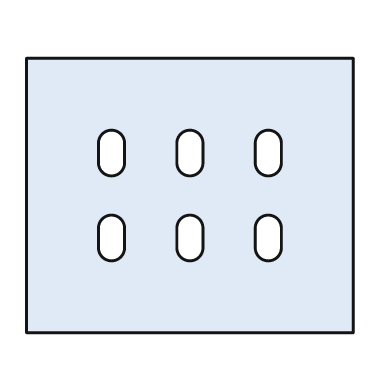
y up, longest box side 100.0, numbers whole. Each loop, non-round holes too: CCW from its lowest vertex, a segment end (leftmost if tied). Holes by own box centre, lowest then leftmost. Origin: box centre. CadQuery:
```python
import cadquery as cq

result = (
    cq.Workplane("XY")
    .moveTo(-50.0, -42.0)
    .lineTo(50.0, -42.0)
    .lineTo(50.0, 42.0)
    .lineTo(-50.0, 42.0)
    .close()
    .moveTo(-28.0, -16.0)
    .threePointArc((-24.0, -20.0), (-20.0, -16.0))
    .lineTo(-20.0, -10.0)
    .threePointArc((-24.0, -6.0), (-28.0, -10.0))
    .close()
    .moveTo(-4.0, -16.0)
    .threePointArc((0.0, -20.0), (4.0, -16.0))
    .lineTo(4.0, -10.0)
    .threePointArc((0.0, -6.0), (-4.0, -10.0))
    .close()
    .moveTo(20.0, -16.0)
    .threePointArc((24.0, -20.0), (28.0, -16.0))
    .lineTo(28.0, -10.0)
    .threePointArc((24.0, -6.0), (20.0, -10.0))
    .close()
    .moveTo(-28.0, 10.0)
    .threePointArc((-24.0, 6.0), (-20.0, 10.0))
    .lineTo(-20.0, 16.0)
    .threePointArc((-24.0, 20.0), (-28.0, 16.0))
    .close()
    .moveTo(-4.0, 10.0)
    .threePointArc((0.0, 6.0), (4.0, 10.0))
    .lineTo(4.0, 16.0)
    .threePointArc((0.0, 20.0), (-4.0, 16.0))
    .close()
    .moveTo(20.0, 10.0)
    .threePointArc((24.0, 6.0), (28.0, 10.0))
    .lineTo(28.0, 16.0)
    .threePointArc((24.0, 20.0), (20.0, 16.0))
    .close()
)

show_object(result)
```